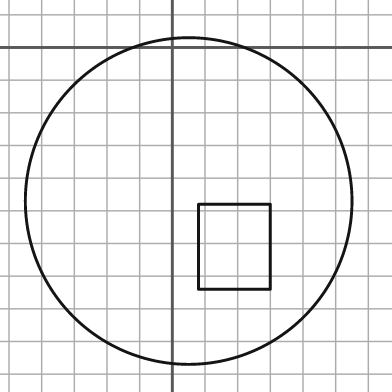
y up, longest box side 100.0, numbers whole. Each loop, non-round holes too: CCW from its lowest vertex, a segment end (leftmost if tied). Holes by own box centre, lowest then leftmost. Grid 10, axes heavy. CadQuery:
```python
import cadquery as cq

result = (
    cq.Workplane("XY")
    .moveTo(5.0, -47.0)
    .circle(50.0)
    .moveTo(8.0, -74.0)
    .lineTo(30.0, -74.0)
    .lineTo(30.0, -48.0)
    .lineTo(8.0, -48.0)
    .close()
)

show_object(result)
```